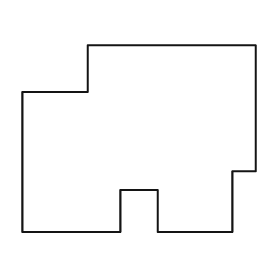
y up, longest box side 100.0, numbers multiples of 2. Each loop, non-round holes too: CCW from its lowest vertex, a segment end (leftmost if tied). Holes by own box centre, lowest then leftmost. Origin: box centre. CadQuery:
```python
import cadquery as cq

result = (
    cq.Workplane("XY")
    .moveTo(-50.0, -40.0)
    .lineTo(-8.0, -40.0)
    .lineTo(-8.0, -22.0)
    .lineTo(8.0, -22.0)
    .lineTo(8.0, -40.0)
    .lineTo(40.0, -40.0)
    .lineTo(40.0, -14.0)
    .lineTo(50.0, -14.0)
    .lineTo(50.0, 40.0)
    .lineTo(-22.0, 40.0)
    .lineTo(-22.0, 20.0)
    .lineTo(-50.0, 20.0)
    .close()
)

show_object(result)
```